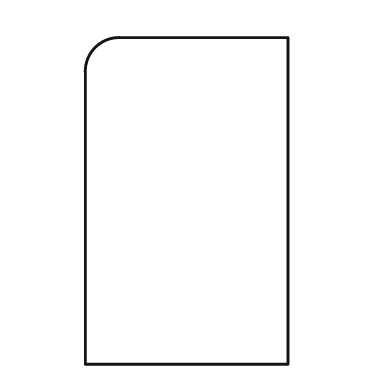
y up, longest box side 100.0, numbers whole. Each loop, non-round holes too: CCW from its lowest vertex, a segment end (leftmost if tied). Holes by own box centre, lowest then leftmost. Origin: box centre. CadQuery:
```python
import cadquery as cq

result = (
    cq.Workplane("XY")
    .moveTo(-31.0, -50.0)
    .lineTo(31.0, -50.0)
    .lineTo(31.0, 50.0)
    .lineTo(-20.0, 50.0)
    .threePointArc((-28.0, 47.0), (-31.0, 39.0))
    .close()
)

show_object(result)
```